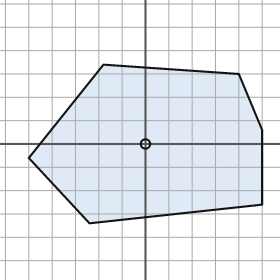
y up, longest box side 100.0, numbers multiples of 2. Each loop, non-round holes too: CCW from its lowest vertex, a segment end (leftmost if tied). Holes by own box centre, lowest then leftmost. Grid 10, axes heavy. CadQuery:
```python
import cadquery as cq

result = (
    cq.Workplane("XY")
    .moveTo(-24.0, -34.0)
    .lineTo(50.0, -26.0)
    .lineTo(50.0, 6.0)
    .lineTo(40.0, 30.0)
    .lineTo(-18.0, 34.0)
    .lineTo(-50.0, -6.0)
    .close()
    .moveTo(0.0, 0.0)
    .circle(2.0)
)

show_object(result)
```